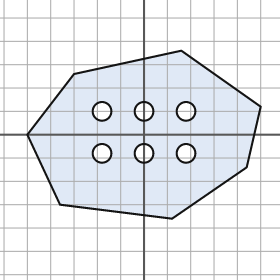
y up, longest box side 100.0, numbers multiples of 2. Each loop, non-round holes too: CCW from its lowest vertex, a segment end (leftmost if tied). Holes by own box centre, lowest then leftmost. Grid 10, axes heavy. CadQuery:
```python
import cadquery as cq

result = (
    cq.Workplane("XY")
    .moveTo(12.0, -36.0)
    .lineTo(44.0, -14.0)
    .lineTo(50.0, 12.0)
    .lineTo(16.0, 36.0)
    .lineTo(-30.0, 26.0)
    .lineTo(-50.0, 0.0)
    .lineTo(-36.0, -30.0)
    .close()
    .moveTo(-18.0, -8.0)
    .circle(4.0)
    .moveTo(0.0, -8.0)
    .circle(4.0)
    .moveTo(18.0, -8.0)
    .circle(4.0)
    .moveTo(-18.0, 10.0)
    .circle(4.0)
    .moveTo(0.0, 10.0)
    .circle(4.0)
    .moveTo(18.0, 10.0)
    .circle(4.0)
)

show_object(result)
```